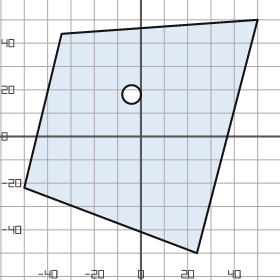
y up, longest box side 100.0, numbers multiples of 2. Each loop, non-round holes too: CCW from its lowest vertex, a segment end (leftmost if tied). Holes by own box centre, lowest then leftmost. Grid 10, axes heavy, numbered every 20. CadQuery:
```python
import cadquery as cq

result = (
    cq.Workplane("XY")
    .moveTo(24.0, -50.0)
    .lineTo(50.0, 50.0)
    .lineTo(-34.0, 44.0)
    .lineTo(-50.0, -22.0)
    .close()
    .moveTo(-4.0, 18.0)
    .circle(4.0)
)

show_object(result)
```